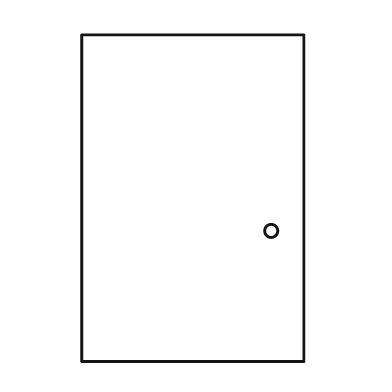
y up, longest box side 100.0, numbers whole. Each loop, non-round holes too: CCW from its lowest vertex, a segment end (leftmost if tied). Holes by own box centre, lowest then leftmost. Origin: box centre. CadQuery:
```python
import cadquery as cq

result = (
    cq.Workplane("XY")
    .moveTo(-34.0, -50.0)
    .lineTo(34.0, -50.0)
    .lineTo(34.0, 50.0)
    .lineTo(-34.0, 50.0)
    .close()
    .moveTo(24.0, -10.0)
    .circle(2.0)
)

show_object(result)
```